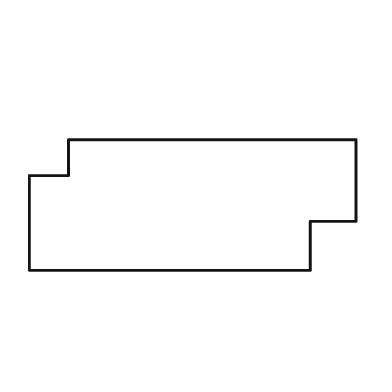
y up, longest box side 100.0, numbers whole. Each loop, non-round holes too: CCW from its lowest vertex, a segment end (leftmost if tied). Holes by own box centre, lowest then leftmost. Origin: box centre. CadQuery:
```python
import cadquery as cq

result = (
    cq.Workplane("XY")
    .moveTo(-50.0, -20.0)
    .lineTo(36.0, -20.0)
    .lineTo(36.0, -5.0)
    .lineTo(50.0, -5.0)
    .lineTo(50.0, 20.0)
    .lineTo(-38.0, 20.0)
    .lineTo(-38.0, 9.0)
    .lineTo(-50.0, 9.0)
    .close()
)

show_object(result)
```